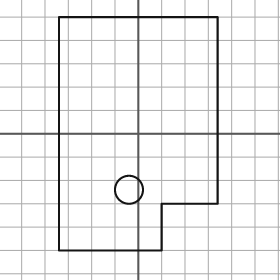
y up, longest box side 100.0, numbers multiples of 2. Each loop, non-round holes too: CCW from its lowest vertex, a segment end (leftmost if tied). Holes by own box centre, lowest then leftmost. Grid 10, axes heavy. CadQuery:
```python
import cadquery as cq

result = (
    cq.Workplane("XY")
    .moveTo(-34.0, -50.0)
    .lineTo(10.0, -50.0)
    .lineTo(10.0, -30.0)
    .lineTo(34.0, -30.0)
    .lineTo(34.0, 50.0)
    .lineTo(-34.0, 50.0)
    .close()
    .moveTo(-4.0, -24.0)
    .circle(6.0)
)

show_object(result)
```